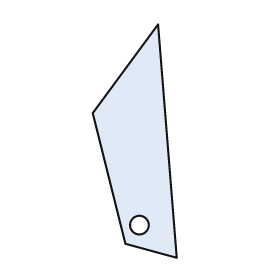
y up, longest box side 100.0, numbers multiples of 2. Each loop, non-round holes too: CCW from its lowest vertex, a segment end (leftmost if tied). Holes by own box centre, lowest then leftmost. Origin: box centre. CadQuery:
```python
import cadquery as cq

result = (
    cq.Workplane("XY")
    .moveTo(18.0, -50.0)
    .lineTo(10.0, 50.0)
    .lineTo(-18.0, 12.0)
    .lineTo(-4.0, -44.0)
    .close()
    .moveTo(2.0, -36.0)
    .circle(4.0)
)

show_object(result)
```